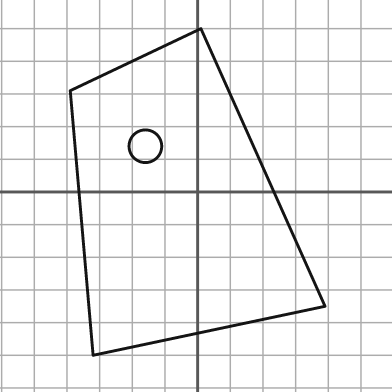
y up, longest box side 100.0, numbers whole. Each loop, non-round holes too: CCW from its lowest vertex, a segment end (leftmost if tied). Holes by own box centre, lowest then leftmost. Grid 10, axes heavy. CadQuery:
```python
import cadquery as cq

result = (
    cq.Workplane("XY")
    .moveTo(-32.0, -50.0)
    .lineTo(39.0, -35.0)
    .lineTo(1.0, 50.0)
    .lineTo(-39.0, 31.0)
    .close()
    .moveTo(-16.0, 14.0)
    .circle(5.0)
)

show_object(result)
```